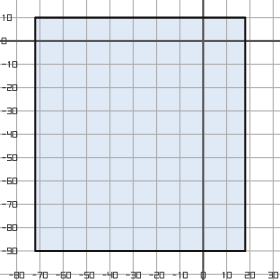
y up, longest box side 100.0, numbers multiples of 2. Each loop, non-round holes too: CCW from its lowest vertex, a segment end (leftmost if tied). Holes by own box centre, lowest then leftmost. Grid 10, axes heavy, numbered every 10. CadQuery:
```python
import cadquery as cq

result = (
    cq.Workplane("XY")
    .moveTo(-72.0, -90.0)
    .lineTo(18.0, -90.0)
    .lineTo(18.0, 10.0)
    .lineTo(-72.0, 10.0)
    .close()
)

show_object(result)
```